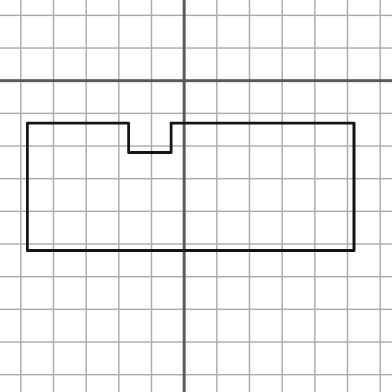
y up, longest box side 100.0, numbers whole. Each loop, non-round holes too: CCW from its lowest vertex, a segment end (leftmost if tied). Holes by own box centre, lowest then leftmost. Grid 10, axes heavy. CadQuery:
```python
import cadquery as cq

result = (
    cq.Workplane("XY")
    .moveTo(-48.0, -52.0)
    .lineTo(52.0, -52.0)
    .lineTo(52.0, -13.0)
    .lineTo(-4.0, -13.0)
    .lineTo(-4.0, -22.0)
    .lineTo(-17.0, -22.0)
    .lineTo(-17.0, -13.0)
    .lineTo(-48.0, -13.0)
    .close()
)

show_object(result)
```